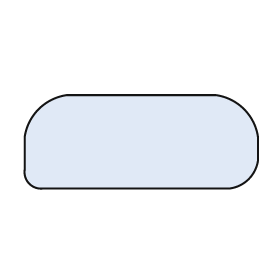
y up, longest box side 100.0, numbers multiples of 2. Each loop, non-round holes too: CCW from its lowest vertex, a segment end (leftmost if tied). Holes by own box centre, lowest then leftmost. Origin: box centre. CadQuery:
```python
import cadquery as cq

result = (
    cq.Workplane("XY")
    .moveTo(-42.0, -20.0)
    .lineTo(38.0, -20.0)
    .threePointArc((46.0, -16.0), (50.0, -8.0))
    .lineTo(50.0, 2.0)
    .threePointArc((44.0, 14.0), (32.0, 20.0))
    .lineTo(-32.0, 20.0)
    .threePointArc((-44.0, 14.0), (-50.0, 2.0))
    .lineTo(-50.0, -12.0)
    .threePointArc((-48.0, -18.0), (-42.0, -20.0))
    .close()
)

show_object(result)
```